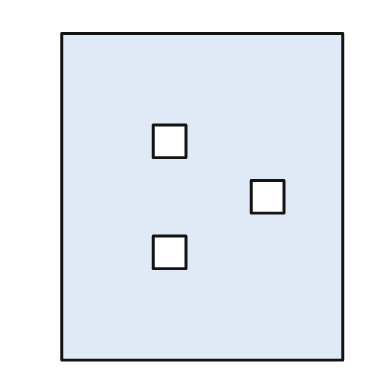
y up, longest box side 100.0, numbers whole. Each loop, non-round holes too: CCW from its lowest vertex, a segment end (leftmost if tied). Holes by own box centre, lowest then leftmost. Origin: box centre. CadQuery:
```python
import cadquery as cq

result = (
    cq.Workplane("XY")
    .moveTo(-43.0, -50.0)
    .lineTo(43.0, -50.0)
    .lineTo(43.0, 50.0)
    .lineTo(-43.0, 50.0)
    .close()
    .moveTo(-15.0, -22.0)
    .lineTo(-5.0, -22.0)
    .lineTo(-5.0, -12.0)
    .lineTo(-15.0, -12.0)
    .close()
    .moveTo(15.0, -5.0)
    .lineTo(25.0, -5.0)
    .lineTo(25.0, 5.0)
    .lineTo(15.0, 5.0)
    .close()
    .moveTo(-15.0, 12.0)
    .lineTo(-5.0, 12.0)
    .lineTo(-5.0, 22.0)
    .lineTo(-15.0, 22.0)
    .close()
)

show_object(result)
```